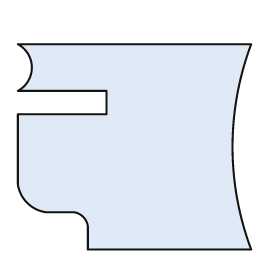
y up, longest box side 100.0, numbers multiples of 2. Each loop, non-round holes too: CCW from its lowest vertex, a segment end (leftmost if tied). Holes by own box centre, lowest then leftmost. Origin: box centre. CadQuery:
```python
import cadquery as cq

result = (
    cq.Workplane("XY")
    .moveTo(-20.0, -44.0)
    .lineTo(50.0, -44.0)
    .threePointArc((42.0, 0.0), (50.0, 44.0))
    .lineTo(-50.0, 44.0)
    .threePointArc((-44.0, 34.0), (-50.0, 24.0))
    .lineTo(-12.0, 24.0)
    .lineTo(-12.0, 14.0)
    .lineTo(-50.0, 14.0)
    .lineTo(-50.0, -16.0)
    .threePointArc((-46.0, -24.0), (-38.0, -28.0))
    .lineTo(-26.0, -28.0)
    .threePointArc((-22.0, -30.0), (-20.0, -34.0))
    .close()
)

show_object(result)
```